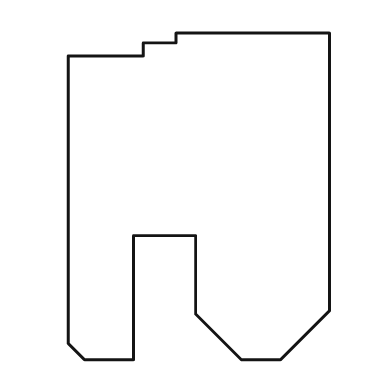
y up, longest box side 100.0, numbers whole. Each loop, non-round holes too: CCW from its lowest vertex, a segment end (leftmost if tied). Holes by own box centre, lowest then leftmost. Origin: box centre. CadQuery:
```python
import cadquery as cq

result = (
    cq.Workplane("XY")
    .moveTo(-35.0, -50.0)
    .lineTo(-20.0, -50.0)
    .lineTo(-20.0, -12.0)
    .lineTo(-1.0, -12.0)
    .lineTo(-1.0, -36.0)
    .lineTo(13.0, -50.0)
    .lineTo(25.0, -50.0)
    .lineTo(40.0, -35.0)
    .lineTo(40.0, 50.0)
    .lineTo(-7.0, 50.0)
    .lineTo(-7.0, 47.0)
    .lineTo(-17.0, 47.0)
    .lineTo(-17.0, 43.0)
    .lineTo(-40.0, 43.0)
    .lineTo(-40.0, -45.0)
    .close()
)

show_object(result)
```